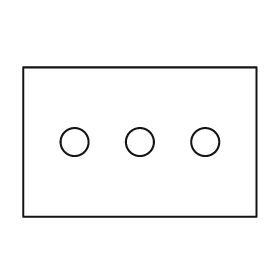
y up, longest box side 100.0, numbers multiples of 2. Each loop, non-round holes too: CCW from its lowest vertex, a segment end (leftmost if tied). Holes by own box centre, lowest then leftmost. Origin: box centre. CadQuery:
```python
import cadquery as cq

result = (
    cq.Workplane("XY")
    .moveTo(-50.0, -32.0)
    .lineTo(50.0, -32.0)
    .lineTo(50.0, 32.0)
    .lineTo(-50.0, 32.0)
    .close()
    .moveTo(-28.0, 0.0)
    .circle(6.0)
    .moveTo(0.0, 0.0)
    .circle(6.0)
    .moveTo(28.0, 0.0)
    .circle(6.0)
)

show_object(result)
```